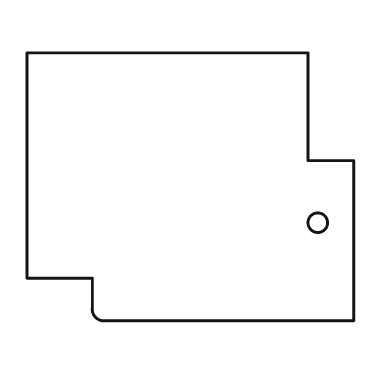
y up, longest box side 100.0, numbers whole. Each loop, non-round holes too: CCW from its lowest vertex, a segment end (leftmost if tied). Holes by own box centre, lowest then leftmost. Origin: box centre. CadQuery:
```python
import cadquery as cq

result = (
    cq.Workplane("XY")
    .moveTo(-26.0, -41.0)
    .lineTo(50.0, -41.0)
    .lineTo(50.0, 8.0)
    .lineTo(36.0, 8.0)
    .lineTo(36.0, 41.0)
    .lineTo(-50.0, 41.0)
    .lineTo(-50.0, -28.0)
    .lineTo(-30.0, -28.0)
    .lineTo(-30.0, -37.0)
    .threePointArc((-29.0, -40.0), (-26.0, -41.0))
    .close()
    .moveTo(39.0, -11.0)
    .circle(3.0)
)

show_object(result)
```